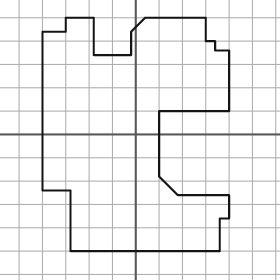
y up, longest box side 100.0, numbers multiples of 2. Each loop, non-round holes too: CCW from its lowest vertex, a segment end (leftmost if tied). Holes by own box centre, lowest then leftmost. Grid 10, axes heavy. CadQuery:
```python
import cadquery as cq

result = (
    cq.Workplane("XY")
    .moveTo(-28.0, -50.0)
    .lineTo(36.0, -50.0)
    .lineTo(36.0, -36.0)
    .lineTo(40.0, -36.0)
    .lineTo(40.0, -26.0)
    .lineTo(18.0, -26.0)
    .lineTo(10.0, -18.0)
    .lineTo(10.0, 10.0)
    .lineTo(40.0, 10.0)
    .lineTo(40.0, 36.0)
    .lineTo(34.0, 36.0)
    .lineTo(34.0, 40.0)
    .lineTo(30.0, 40.0)
    .lineTo(30.0, 50.0)
    .lineTo(4.0, 50.0)
    .lineTo(-2.0, 44.0)
    .lineTo(-2.0, 34.0)
    .lineTo(-18.0, 34.0)
    .lineTo(-18.0, 50.0)
    .lineTo(-30.0, 50.0)
    .lineTo(-30.0, 44.0)
    .lineTo(-40.0, 44.0)
    .lineTo(-40.0, -24.0)
    .lineTo(-28.0, -24.0)
    .close()
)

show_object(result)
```